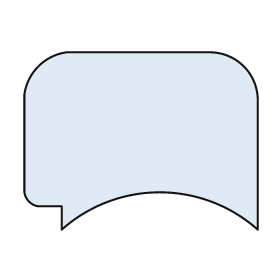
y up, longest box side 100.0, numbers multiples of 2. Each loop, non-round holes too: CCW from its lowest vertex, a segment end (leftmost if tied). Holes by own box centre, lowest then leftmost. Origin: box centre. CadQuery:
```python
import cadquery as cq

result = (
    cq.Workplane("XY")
    .moveTo(-34.0, -38.0)
    .threePointArc((8.0, -22.0), (50.0, -38.0))
    .lineTo(50.0, 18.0)
    .threePointArc((44.0, 32.0), (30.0, 38.0))
    .lineTo(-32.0, 38.0)
    .threePointArc((-44.0, 32.0), (-50.0, 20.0))
    .lineTo(-50.0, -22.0)
    .threePointArc((-48.0, -26.0), (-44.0, -28.0))
    .lineTo(-34.0, -28.0)
    .close()
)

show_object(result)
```